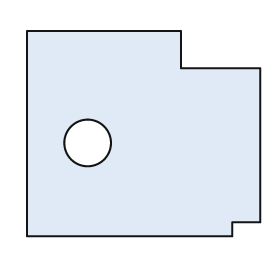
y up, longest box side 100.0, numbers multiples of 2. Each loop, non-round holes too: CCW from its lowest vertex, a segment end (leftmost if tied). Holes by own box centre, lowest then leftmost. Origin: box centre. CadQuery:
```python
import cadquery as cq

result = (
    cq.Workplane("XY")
    .moveTo(-50.0, -44.0)
    .lineTo(38.0, -44.0)
    .lineTo(38.0, -38.0)
    .lineTo(50.0, -38.0)
    .lineTo(50.0, 28.0)
    .lineTo(16.0, 28.0)
    .lineTo(16.0, 44.0)
    .lineTo(-50.0, 44.0)
    .close()
    .moveTo(-24.0, -4.0)
    .circle(10.0)
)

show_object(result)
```